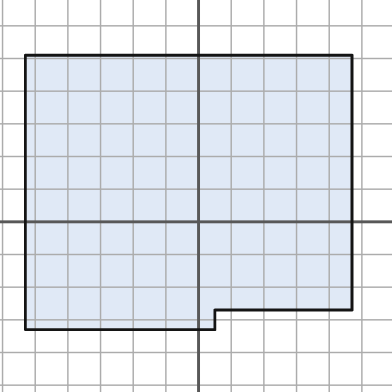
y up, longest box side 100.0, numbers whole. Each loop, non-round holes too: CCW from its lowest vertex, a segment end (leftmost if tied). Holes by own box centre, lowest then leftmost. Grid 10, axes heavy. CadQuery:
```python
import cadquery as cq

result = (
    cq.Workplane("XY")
    .moveTo(-53.0, -33.0)
    .lineTo(5.0, -33.0)
    .lineTo(5.0, -27.0)
    .lineTo(47.0, -27.0)
    .lineTo(47.0, 51.0)
    .lineTo(-53.0, 51.0)
    .close()
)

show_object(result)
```